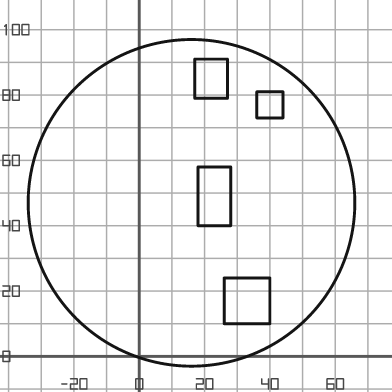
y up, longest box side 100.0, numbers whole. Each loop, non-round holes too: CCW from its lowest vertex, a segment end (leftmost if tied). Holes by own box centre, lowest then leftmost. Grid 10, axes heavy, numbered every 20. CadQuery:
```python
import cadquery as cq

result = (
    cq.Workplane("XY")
    .moveTo(16.0, 47.0)
    .circle(50.0)
    .moveTo(26.0, 10.0)
    .lineTo(40.0, 10.0)
    .lineTo(40.0, 24.0)
    .lineTo(26.0, 24.0)
    .close()
    .moveTo(18.0, 40.0)
    .lineTo(28.0, 40.0)
    .lineTo(28.0, 58.0)
    .lineTo(18.0, 58.0)
    .close()
    .moveTo(36.0, 73.0)
    .lineTo(44.0, 73.0)
    .lineTo(44.0, 81.0)
    .lineTo(36.0, 81.0)
    .close()
    .moveTo(17.0, 79.0)
    .lineTo(27.0, 79.0)
    .lineTo(27.0, 91.0)
    .lineTo(17.0, 91.0)
    .close()
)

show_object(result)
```